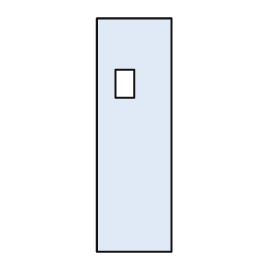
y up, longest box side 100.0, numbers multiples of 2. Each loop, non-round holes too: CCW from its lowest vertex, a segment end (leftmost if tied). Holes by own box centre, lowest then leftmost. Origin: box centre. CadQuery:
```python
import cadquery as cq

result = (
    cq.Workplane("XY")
    .moveTo(-16.0, -50.0)
    .lineTo(16.0, -50.0)
    .lineTo(16.0, 50.0)
    .lineTo(-16.0, 50.0)
    .close()
    .moveTo(-8.0, 16.0)
    .lineTo(0.0, 16.0)
    .lineTo(0.0, 28.0)
    .lineTo(-8.0, 28.0)
    .close()
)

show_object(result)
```